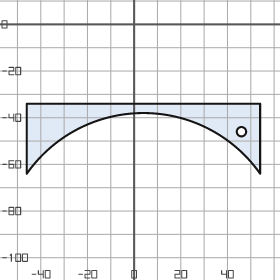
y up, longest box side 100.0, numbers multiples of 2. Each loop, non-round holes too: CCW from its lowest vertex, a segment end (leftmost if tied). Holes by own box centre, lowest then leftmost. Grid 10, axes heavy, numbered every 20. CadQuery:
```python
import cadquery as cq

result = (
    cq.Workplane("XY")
    .moveTo(-46.0, -64.0)
    .threePointArc((4.0, -38.0), (54.0, -64.0))
    .lineTo(54.0, -34.0)
    .lineTo(-46.0, -34.0)
    .close()
    .moveTo(46.0, -46.0)
    .circle(2.0)
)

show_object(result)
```